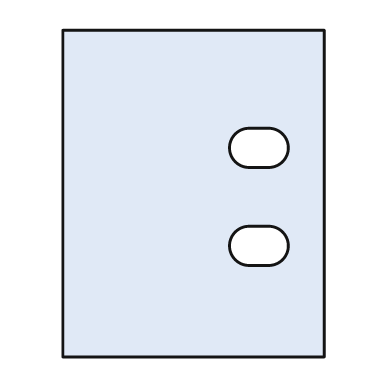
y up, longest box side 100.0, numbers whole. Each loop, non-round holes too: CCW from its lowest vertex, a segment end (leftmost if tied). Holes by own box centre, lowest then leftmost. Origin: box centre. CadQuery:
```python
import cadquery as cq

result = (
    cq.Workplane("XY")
    .moveTo(-40.0, -50.0)
    .lineTo(40.0, -50.0)
    .lineTo(40.0, 50.0)
    .lineTo(-40.0, 50.0)
    .close()
    .moveTo(17.0, -22.0)
    .lineTo(23.0, -22.0)
    .threePointArc((29.0, -16.0), (23.0, -10.0))
    .lineTo(17.0, -10.0)
    .threePointArc((11.0, -16.0), (17.0, -22.0))
    .close()
    .moveTo(17.0, 8.0)
    .lineTo(23.0, 8.0)
    .threePointArc((29.0, 14.0), (23.0, 20.0))
    .lineTo(17.0, 20.0)
    .threePointArc((11.0, 14.0), (17.0, 8.0))
    .close()
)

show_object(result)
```